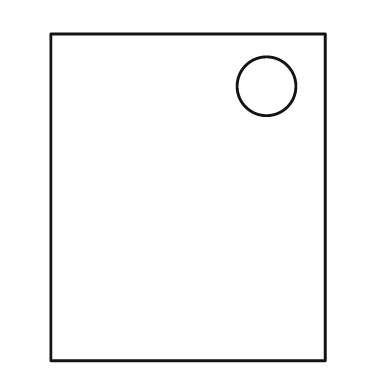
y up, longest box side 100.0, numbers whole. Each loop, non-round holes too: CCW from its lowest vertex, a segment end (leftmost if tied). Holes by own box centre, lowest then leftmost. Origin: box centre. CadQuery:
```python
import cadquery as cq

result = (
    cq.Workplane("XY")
    .moveTo(-42.0, -50.0)
    .lineTo(42.0, -50.0)
    .lineTo(42.0, 50.0)
    .lineTo(-42.0, 50.0)
    .close()
    .moveTo(24.0, 34.0)
    .circle(9.0)
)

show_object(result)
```